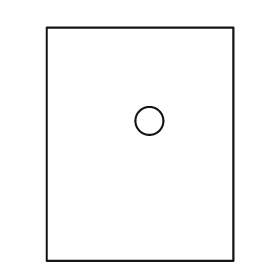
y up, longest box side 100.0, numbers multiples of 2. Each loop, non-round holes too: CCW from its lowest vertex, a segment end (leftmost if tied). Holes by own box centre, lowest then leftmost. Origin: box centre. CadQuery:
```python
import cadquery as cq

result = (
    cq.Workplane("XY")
    .moveTo(-40.0, -50.0)
    .lineTo(40.0, -50.0)
    .lineTo(40.0, 50.0)
    .lineTo(-40.0, 50.0)
    .close()
    .moveTo(4.0, 10.0)
    .circle(6.0)
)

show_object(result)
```